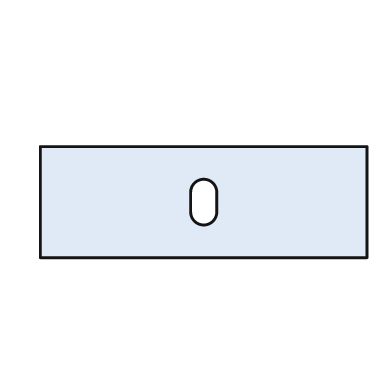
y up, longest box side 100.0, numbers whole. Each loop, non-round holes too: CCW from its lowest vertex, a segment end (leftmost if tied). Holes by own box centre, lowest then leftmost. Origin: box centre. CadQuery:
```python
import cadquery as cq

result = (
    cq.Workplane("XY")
    .moveTo(-50.0, -17.0)
    .lineTo(50.0, -17.0)
    .lineTo(50.0, 17.0)
    .lineTo(-50.0, 17.0)
    .close()
    .moveTo(-4.0, -3.0)
    .threePointArc((0.0, -7.0), (4.0, -3.0))
    .lineTo(4.0, 3.0)
    .threePointArc((0.0, 7.0), (-4.0, 3.0))
    .close()
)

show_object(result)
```